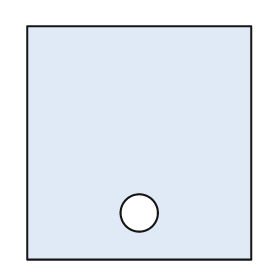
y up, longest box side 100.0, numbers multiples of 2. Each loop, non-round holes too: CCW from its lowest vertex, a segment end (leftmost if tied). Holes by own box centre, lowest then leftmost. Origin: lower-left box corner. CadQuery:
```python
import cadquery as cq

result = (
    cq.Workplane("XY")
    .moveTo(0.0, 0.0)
    .lineTo(96.0, 0.0)
    .lineTo(96.0, 100.0)
    .lineTo(0.0, 100.0)
    .close()
    .moveTo(48.0, 20.0)
    .circle(8.0)
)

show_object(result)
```